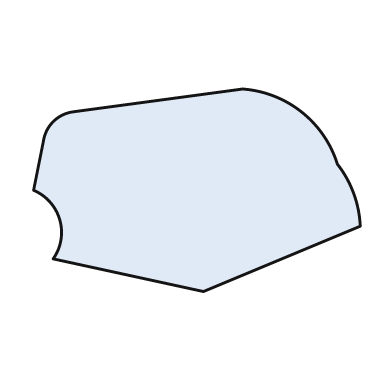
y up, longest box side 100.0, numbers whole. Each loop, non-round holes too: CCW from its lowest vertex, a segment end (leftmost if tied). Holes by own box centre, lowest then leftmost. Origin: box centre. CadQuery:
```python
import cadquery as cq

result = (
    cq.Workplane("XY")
    .moveTo(2.0, -31.0)
    .lineTo(50.0, -11.0)
    .threePointArc((48.0, -1.0), (43.0, 8.0))
    .threePointArc((32.0, 24.0), (14.0, 31.0))
    .lineTo(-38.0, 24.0)
    .threePointArc((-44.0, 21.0), (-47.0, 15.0))
    .lineTo(-50.0, 0.0)
    .threePointArc((-42.0, -9.0), (-44.0, -21.0))
    .close()
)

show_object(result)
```